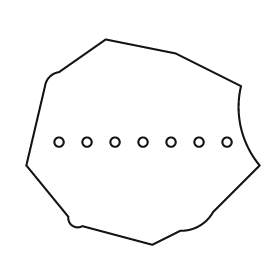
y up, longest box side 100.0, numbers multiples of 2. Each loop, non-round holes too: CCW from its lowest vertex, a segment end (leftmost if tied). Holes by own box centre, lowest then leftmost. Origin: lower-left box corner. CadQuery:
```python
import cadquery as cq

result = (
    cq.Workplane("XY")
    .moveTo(54.0, 0.0)
    .lineTo(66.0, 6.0)
    .threePointArc((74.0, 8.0), (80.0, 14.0))
    .lineTo(100.0, 34.0)
    .threePointArc((92.0, 50.0), (92.0, 68.0))
    .lineTo(64.0, 82.0)
    .lineTo(34.0, 88.0)
    .lineTo(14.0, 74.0)
    .threePointArc((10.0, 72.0), (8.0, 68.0))
    .lineTo(0.0, 34.0)
    .lineTo(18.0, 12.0)
    .threePointArc((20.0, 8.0), (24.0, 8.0))
    .close()
    .moveTo(14.0, 44.0)
    .circle(2.0)
    .moveTo(26.0, 44.0)
    .circle(2.0)
    .moveTo(38.0, 44.0)
    .circle(2.0)
    .moveTo(50.0, 44.0)
    .circle(2.0)
    .moveTo(62.0, 44.0)
    .circle(2.0)
    .moveTo(74.0, 44.0)
    .circle(2.0)
    .moveTo(86.0, 44.0)
    .circle(2.0)
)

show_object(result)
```